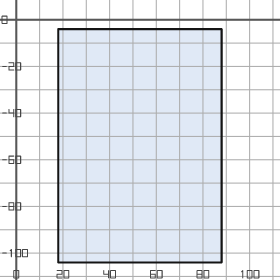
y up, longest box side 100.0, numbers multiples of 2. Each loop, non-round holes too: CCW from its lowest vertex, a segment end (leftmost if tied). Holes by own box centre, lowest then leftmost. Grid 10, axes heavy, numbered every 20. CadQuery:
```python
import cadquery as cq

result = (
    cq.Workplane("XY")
    .moveTo(18.0, -104.0)
    .lineTo(88.0, -104.0)
    .lineTo(88.0, -4.0)
    .lineTo(18.0, -4.0)
    .close()
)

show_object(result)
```